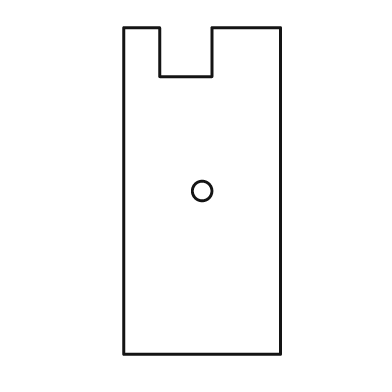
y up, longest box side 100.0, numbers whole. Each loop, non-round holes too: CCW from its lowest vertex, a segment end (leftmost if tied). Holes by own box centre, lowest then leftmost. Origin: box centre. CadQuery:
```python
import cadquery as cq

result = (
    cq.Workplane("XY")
    .moveTo(-24.0, -50.0)
    .lineTo(24.0, -50.0)
    .lineTo(24.0, 50.0)
    .lineTo(3.0, 50.0)
    .lineTo(3.0, 35.0)
    .lineTo(-13.0, 35.0)
    .lineTo(-13.0, 50.0)
    .lineTo(-24.0, 50.0)
    .close()
    .moveTo(0.0, 0.0)
    .circle(3.0)
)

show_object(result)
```